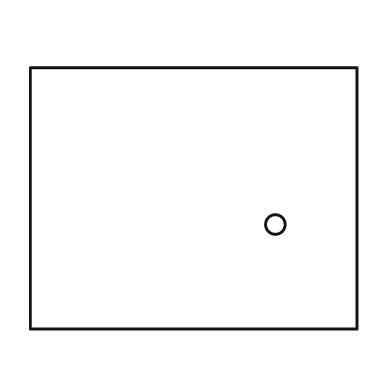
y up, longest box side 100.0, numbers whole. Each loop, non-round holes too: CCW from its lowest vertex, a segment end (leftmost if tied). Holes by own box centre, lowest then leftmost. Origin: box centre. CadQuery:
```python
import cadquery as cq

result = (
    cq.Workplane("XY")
    .moveTo(-50.0, -40.0)
    .lineTo(50.0, -40.0)
    .lineTo(50.0, 40.0)
    .lineTo(-50.0, 40.0)
    .close()
    .moveTo(25.0, -8.0)
    .circle(3.0)
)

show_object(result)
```